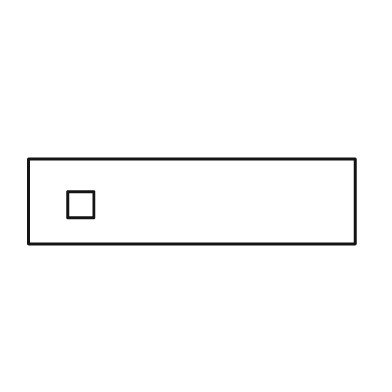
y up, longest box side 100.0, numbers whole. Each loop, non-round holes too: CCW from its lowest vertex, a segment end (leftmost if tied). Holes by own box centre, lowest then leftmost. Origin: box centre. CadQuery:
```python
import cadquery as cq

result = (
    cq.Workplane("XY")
    .moveTo(-50.0, -13.0)
    .lineTo(50.0, -13.0)
    .lineTo(50.0, 13.0)
    .lineTo(-50.0, 13.0)
    .close()
    .moveTo(-38.0, -5.0)
    .lineTo(-30.0, -5.0)
    .lineTo(-30.0, 3.0)
    .lineTo(-38.0, 3.0)
    .close()
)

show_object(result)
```